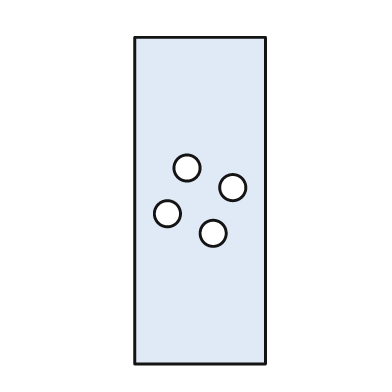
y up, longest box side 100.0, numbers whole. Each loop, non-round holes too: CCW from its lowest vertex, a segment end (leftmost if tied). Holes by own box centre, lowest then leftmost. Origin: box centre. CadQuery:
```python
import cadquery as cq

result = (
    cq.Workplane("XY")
    .moveTo(-20.0, -50.0)
    .lineTo(20.0, -50.0)
    .lineTo(20.0, 50.0)
    .lineTo(-20.0, 50.0)
    .close()
    .moveTo(4.0, -10.0)
    .circle(4.0)
    .moveTo(-10.0, -4.0)
    .circle(4.0)
    .moveTo(10.0, 4.0)
    .circle(4.0)
    .moveTo(-4.0, 10.0)
    .circle(4.0)
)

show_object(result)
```